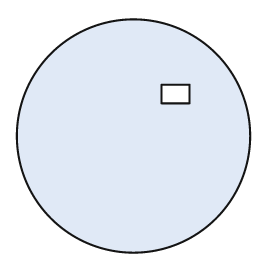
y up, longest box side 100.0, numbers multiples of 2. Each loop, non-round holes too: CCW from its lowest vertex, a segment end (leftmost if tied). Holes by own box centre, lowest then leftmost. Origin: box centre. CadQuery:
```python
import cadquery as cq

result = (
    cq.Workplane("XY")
    .moveTo(0.0, 0.0)
    .circle(50.0)
    .moveTo(12.0, 14.0)
    .lineTo(24.0, 14.0)
    .lineTo(24.0, 22.0)
    .lineTo(12.0, 22.0)
    .close()
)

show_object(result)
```